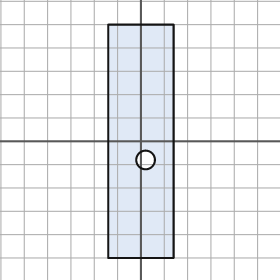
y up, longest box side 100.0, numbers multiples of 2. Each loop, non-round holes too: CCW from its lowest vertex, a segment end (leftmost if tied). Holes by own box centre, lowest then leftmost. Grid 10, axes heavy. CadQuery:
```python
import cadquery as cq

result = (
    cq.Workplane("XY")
    .moveTo(-14.0, -50.0)
    .lineTo(14.0, -50.0)
    .lineTo(14.0, 50.0)
    .lineTo(-14.0, 50.0)
    .close()
    .moveTo(2.0, -8.0)
    .circle(4.0)
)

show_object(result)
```